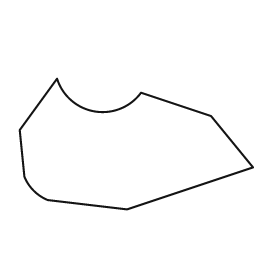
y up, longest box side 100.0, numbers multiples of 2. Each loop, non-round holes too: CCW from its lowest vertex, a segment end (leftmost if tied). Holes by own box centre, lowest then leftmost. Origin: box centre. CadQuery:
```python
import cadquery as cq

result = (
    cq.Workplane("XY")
    .moveTo(-4.0, -28.0)
    .lineTo(50.0, -10.0)
    .lineTo(32.0, 12.0)
    .lineTo(2.0, 22.0)
    .threePointArc((-18.0, 14.0), (-34.0, 28.0))
    .lineTo(-50.0, 6.0)
    .lineTo(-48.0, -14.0)
    .threePointArc((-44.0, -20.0), (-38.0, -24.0))
    .close()
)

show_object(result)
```